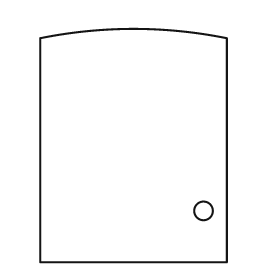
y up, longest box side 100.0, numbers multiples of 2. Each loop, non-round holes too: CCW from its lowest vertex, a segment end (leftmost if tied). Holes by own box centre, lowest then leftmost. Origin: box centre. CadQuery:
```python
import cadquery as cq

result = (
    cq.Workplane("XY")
    .moveTo(-40.0, -50.0)
    .lineTo(40.0, -50.0)
    .lineTo(40.0, 46.0)
    .threePointArc((0.0, 50.0), (-40.0, 46.0))
    .close()
    .moveTo(30.0, -28.0)
    .circle(4.0)
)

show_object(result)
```